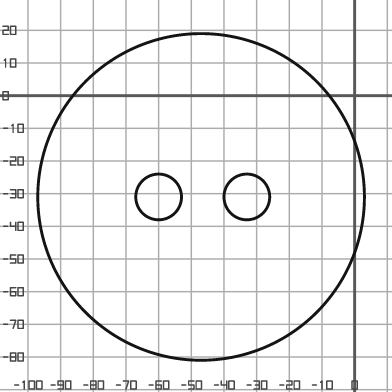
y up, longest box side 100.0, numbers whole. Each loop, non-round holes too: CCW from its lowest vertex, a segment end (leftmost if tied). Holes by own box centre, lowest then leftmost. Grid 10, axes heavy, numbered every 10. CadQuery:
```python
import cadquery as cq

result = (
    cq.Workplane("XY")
    .moveTo(-47.0, -31.0)
    .circle(50.0)
    .moveTo(-60.0, -31.0)
    .circle(7.0)
    .moveTo(-33.0, -31.0)
    .circle(7.0)
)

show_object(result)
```